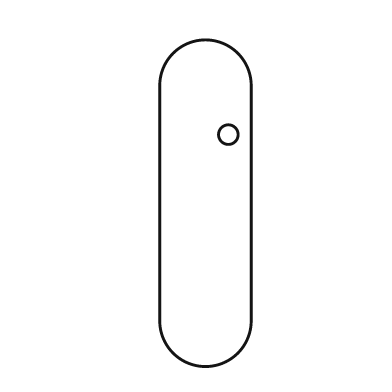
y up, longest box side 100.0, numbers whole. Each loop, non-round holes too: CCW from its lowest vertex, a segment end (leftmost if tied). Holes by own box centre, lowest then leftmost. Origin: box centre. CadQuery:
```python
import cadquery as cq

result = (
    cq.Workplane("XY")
    .moveTo(-14.0, -36.0)
    .threePointArc((0.0, -50.0), (14.0, -36.0))
    .lineTo(14.0, 36.0)
    .threePointArc((0.0, 50.0), (-14.0, 36.0))
    .close()
    .moveTo(7.0, 21.0)
    .circle(3.0)
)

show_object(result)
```